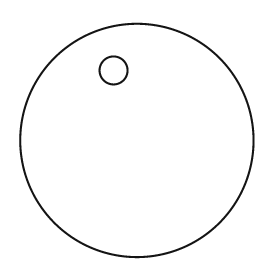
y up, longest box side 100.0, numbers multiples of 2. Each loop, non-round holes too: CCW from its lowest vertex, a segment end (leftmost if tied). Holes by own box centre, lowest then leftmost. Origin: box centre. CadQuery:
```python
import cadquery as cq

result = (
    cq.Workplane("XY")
    .moveTo(0.0, 0.0)
    .circle(50.0)
    .moveTo(-10.0, 30.0)
    .circle(6.0)
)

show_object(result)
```